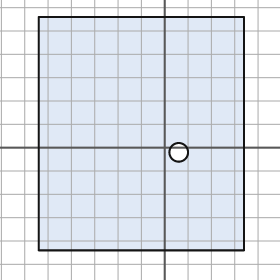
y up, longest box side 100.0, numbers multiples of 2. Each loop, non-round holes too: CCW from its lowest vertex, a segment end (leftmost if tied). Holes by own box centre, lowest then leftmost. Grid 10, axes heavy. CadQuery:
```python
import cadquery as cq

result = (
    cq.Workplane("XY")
    .moveTo(-54.0, -44.0)
    .lineTo(34.0, -44.0)
    .lineTo(34.0, 56.0)
    .lineTo(-54.0, 56.0)
    .close()
    .moveTo(6.0, -2.0)
    .circle(4.0)
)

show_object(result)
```